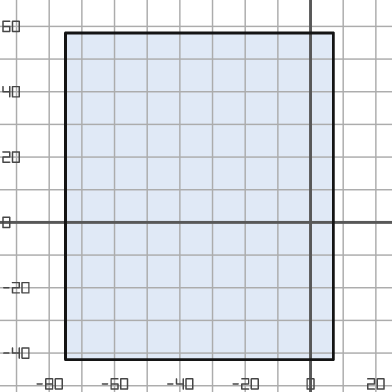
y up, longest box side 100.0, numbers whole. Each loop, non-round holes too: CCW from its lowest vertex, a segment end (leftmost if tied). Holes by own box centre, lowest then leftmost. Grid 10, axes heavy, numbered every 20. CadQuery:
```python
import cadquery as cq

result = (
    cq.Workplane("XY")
    .moveTo(-75.0, -42.0)
    .lineTo(7.0, -42.0)
    .lineTo(7.0, 58.0)
    .lineTo(-75.0, 58.0)
    .close()
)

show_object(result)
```